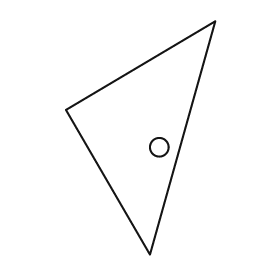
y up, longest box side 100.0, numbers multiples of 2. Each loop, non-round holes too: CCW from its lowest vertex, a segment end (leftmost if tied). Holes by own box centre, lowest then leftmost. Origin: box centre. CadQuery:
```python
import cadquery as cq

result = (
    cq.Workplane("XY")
    .moveTo(4.0, -50.0)
    .lineTo(32.0, 50.0)
    .lineTo(-32.0, 12.0)
    .close()
    .moveTo(8.0, -4.0)
    .circle(4.0)
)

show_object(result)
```